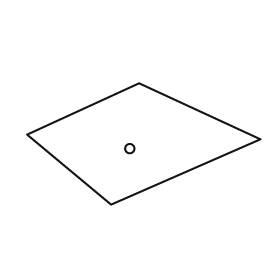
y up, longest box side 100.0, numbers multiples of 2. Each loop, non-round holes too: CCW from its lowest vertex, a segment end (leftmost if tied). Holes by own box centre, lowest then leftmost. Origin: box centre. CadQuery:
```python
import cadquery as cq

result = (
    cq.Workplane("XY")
    .moveTo(-14.0, -26.0)
    .lineTo(50.0, 2.0)
    .lineTo(-2.0, 26.0)
    .lineTo(-50.0, 4.0)
    .close()
    .moveTo(-6.0, -2.0)
    .circle(2.0)
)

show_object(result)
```